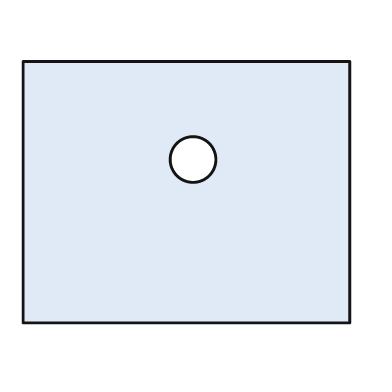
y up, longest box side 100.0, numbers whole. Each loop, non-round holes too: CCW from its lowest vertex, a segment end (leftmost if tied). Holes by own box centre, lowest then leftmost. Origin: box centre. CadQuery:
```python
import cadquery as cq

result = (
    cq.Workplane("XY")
    .moveTo(-50.0, -40.0)
    .lineTo(50.0, -40.0)
    .lineTo(50.0, 40.0)
    .lineTo(-50.0, 40.0)
    .close()
    .moveTo(2.0, 10.0)
    .circle(7.0)
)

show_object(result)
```